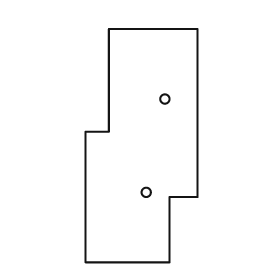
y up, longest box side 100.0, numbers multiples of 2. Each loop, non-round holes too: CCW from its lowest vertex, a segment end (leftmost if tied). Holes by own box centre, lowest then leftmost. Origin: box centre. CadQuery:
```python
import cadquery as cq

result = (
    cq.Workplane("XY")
    .moveTo(-24.0, -50.0)
    .lineTo(12.0, -50.0)
    .lineTo(12.0, -22.0)
    .lineTo(24.0, -22.0)
    .lineTo(24.0, 50.0)
    .lineTo(-14.0, 50.0)
    .lineTo(-14.0, 6.0)
    .lineTo(-24.0, 6.0)
    .close()
    .moveTo(2.0, -20.0)
    .circle(2.0)
    .moveTo(10.0, 20.0)
    .circle(2.0)
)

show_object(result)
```